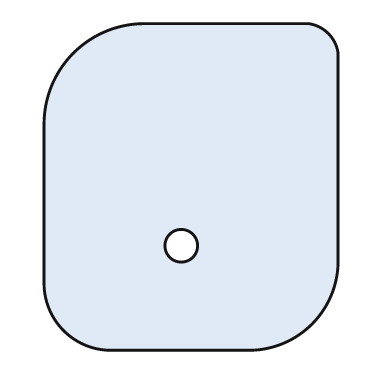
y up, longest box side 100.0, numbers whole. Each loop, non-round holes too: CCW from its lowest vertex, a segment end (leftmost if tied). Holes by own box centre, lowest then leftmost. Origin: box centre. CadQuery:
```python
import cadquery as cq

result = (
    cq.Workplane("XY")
    .moveTo(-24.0, -50.0)
    .lineTo(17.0, -50.0)
    .threePointArc((37.0, -42.0), (45.0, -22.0))
    .lineTo(45.0, 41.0)
    .threePointArc((42.0, 47.0), (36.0, 50.0))
    .lineTo(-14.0, 50.0)
    .threePointArc((-36.0, 41.0), (-45.0, 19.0))
    .lineTo(-45.0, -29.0)
    .threePointArc((-39.0, -44.0), (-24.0, -50.0))
    .close()
    .moveTo(-3.0, -18.0)
    .circle(5.0)
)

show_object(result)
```